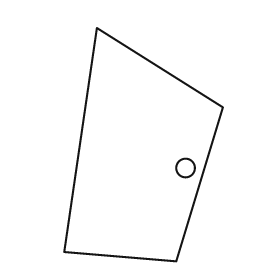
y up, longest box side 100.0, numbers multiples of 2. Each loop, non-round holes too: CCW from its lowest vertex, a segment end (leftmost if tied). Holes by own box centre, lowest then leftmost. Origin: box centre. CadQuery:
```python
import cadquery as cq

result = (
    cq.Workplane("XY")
    .moveTo(14.0, -50.0)
    .lineTo(34.0, 16.0)
    .lineTo(-20.0, 50.0)
    .lineTo(-34.0, -46.0)
    .close()
    .moveTo(18.0, -10.0)
    .circle(4.0)
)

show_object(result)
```